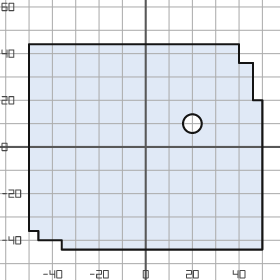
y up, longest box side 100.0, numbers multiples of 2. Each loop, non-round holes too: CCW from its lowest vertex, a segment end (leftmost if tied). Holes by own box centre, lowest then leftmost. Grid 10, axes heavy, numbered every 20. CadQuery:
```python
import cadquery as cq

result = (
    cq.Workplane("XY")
    .moveTo(-36.0, -44.0)
    .lineTo(50.0, -44.0)
    .lineTo(50.0, 20.0)
    .lineTo(46.0, 20.0)
    .lineTo(46.0, 36.0)
    .lineTo(40.0, 36.0)
    .lineTo(40.0, 44.0)
    .lineTo(-50.0, 44.0)
    .lineTo(-50.0, -36.0)
    .lineTo(-46.0, -36.0)
    .lineTo(-46.0, -40.0)
    .lineTo(-36.0, -40.0)
    .close()
    .moveTo(20.0, 10.0)
    .circle(4.0)
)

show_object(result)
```